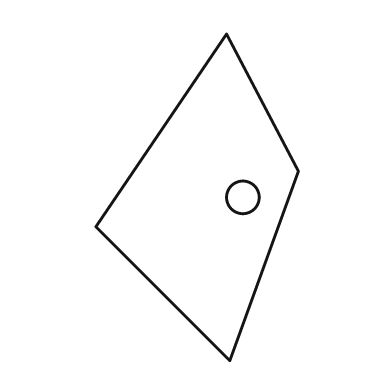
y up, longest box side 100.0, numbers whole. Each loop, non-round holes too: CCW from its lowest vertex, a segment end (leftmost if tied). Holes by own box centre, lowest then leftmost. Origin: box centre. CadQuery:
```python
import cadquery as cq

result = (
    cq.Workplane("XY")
    .moveTo(10.0, -50.0)
    .lineTo(31.0, 8.0)
    .lineTo(9.0, 50.0)
    .lineTo(-31.0, -9.0)
    .close()
    .moveTo(14.0, 0.0)
    .circle(5.0)
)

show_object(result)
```